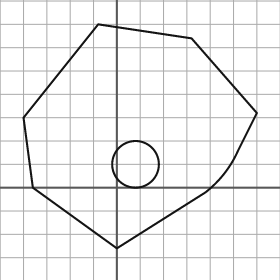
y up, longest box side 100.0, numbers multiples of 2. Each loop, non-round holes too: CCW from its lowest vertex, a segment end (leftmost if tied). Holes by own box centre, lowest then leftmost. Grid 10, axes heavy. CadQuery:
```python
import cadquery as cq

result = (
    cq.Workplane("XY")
    .moveTo(0.0, -26.0)
    .lineTo(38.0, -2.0)
    .threePointArc((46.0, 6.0), (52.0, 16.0))
    .lineTo(60.0, 32.0)
    .lineTo(32.0, 64.0)
    .lineTo(-8.0, 70.0)
    .lineTo(-40.0, 30.0)
    .lineTo(-36.0, 0.0)
    .close()
    .moveTo(8.0, 10.0)
    .circle(10.0)
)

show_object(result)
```